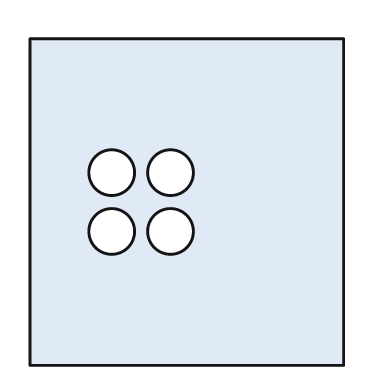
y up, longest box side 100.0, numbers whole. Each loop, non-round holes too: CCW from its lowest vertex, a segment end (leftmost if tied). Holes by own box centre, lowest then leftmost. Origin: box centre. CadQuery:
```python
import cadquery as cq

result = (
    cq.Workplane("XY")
    .moveTo(-48.0, -50.0)
    .lineTo(48.0, -50.0)
    .lineTo(48.0, 50.0)
    .lineTo(-48.0, 50.0)
    .close()
    .moveTo(-23.0, -9.0)
    .circle(7.0)
    .moveTo(-5.0, -9.0)
    .circle(7.0)
    .moveTo(-23.0, 9.0)
    .circle(7.0)
    .moveTo(-5.0, 9.0)
    .circle(7.0)
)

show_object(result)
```